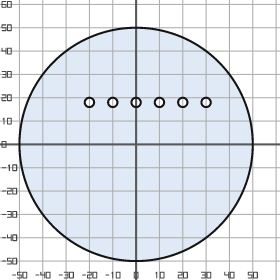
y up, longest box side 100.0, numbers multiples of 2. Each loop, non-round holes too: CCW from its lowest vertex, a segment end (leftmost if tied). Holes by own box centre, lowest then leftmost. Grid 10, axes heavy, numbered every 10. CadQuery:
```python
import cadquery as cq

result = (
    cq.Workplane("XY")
    .moveTo(0.0, 0.0)
    .circle(50.0)
    .moveTo(-20.0, 18.0)
    .circle(2.0)
    .moveTo(-10.0, 18.0)
    .circle(2.0)
    .moveTo(0.0, 18.0)
    .circle(2.0)
    .moveTo(10.0, 18.0)
    .circle(2.0)
    .moveTo(20.0, 18.0)
    .circle(2.0)
    .moveTo(30.0, 18.0)
    .circle(2.0)
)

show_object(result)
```